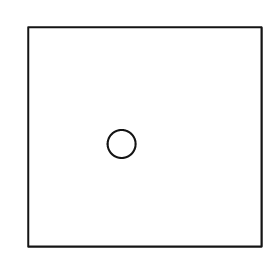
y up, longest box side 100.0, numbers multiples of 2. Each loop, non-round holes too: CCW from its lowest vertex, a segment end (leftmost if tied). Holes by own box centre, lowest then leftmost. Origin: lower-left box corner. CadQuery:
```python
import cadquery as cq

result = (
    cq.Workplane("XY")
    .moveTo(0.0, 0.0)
    .lineTo(100.0, 0.0)
    .lineTo(100.0, 94.0)
    .lineTo(0.0, 94.0)
    .close()
    .moveTo(40.0, 44.0)
    .circle(6.0)
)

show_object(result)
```